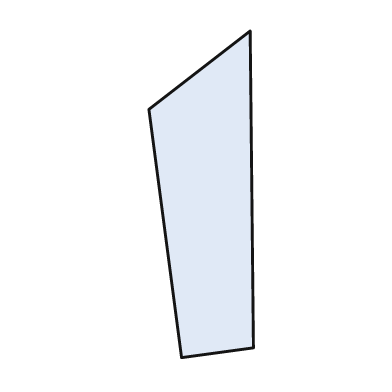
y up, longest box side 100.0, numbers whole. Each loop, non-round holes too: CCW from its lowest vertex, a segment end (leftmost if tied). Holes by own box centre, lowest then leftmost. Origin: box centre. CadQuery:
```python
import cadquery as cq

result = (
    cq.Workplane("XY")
    .moveTo(-6.0, -50.0)
    .lineTo(16.0, -47.0)
    .lineTo(15.0, 50.0)
    .lineTo(-16.0, 26.0)
    .close()
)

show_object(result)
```